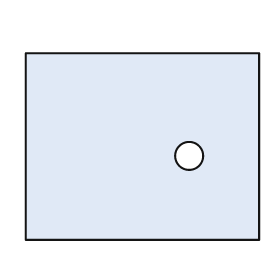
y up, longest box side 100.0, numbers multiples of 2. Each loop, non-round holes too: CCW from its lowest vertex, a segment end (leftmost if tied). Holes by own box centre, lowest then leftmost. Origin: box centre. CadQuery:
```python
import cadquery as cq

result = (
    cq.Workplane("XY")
    .moveTo(-50.0, -40.0)
    .lineTo(50.0, -40.0)
    .lineTo(50.0, 40.0)
    .lineTo(-50.0, 40.0)
    .close()
    .moveTo(20.0, -4.0)
    .circle(6.0)
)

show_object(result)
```